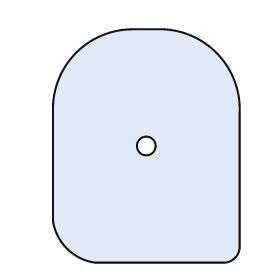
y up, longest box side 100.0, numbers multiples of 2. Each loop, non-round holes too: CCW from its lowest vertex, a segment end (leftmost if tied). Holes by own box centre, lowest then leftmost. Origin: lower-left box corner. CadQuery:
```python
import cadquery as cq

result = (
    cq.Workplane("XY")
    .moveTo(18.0, 0.0)
    .lineTo(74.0, 0.0)
    .threePointArc((78.0, 2.0), (80.0, 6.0))
    .lineTo(80.0, 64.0)
    .threePointArc((70.0, 90.0), (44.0, 100.0))
    .lineTo(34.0, 100.0)
    .threePointArc((10.0, 90.0), (0.0, 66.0))
    .lineTo(0.0, 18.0)
    .threePointArc((6.0, 6.0), (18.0, 0.0))
    .close()
    .moveTo(40.0, 50.0)
    .circle(4.0)
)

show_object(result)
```